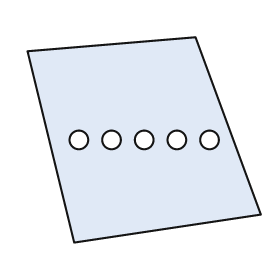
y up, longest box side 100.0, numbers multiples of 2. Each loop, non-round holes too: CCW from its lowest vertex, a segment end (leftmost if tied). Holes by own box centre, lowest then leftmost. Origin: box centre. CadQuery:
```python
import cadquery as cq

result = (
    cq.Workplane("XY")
    .moveTo(-30.0, -44.0)
    .lineTo(50.0, -32.0)
    .lineTo(22.0, 44.0)
    .lineTo(-50.0, 38.0)
    .close()
    .moveTo(-28.0, 0.0)
    .circle(4.0)
    .moveTo(-14.0, 0.0)
    .circle(4.0)
    .moveTo(0.0, 0.0)
    .circle(4.0)
    .moveTo(14.0, 0.0)
    .circle(4.0)
    .moveTo(28.0, 0.0)
    .circle(4.0)
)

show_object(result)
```